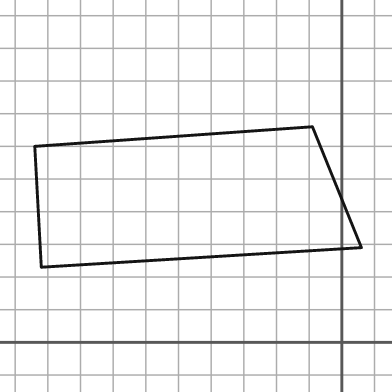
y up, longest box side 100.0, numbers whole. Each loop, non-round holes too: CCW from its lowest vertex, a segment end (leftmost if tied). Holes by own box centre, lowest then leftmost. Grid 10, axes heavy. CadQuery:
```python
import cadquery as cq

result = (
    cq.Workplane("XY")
    .moveTo(-92.0, 23.0)
    .lineTo(6.0, 29.0)
    .lineTo(-9.0, 66.0)
    .lineTo(-94.0, 60.0)
    .close()
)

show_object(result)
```